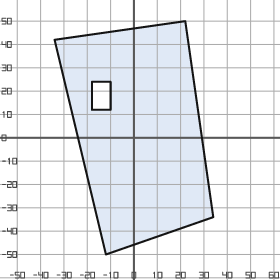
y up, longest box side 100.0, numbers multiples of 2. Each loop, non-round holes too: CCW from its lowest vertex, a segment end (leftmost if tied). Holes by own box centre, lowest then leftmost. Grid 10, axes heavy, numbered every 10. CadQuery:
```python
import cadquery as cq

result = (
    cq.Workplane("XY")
    .moveTo(-12.0, -50.0)
    .lineTo(34.0, -34.0)
    .lineTo(22.0, 50.0)
    .lineTo(-34.0, 42.0)
    .close()
    .moveTo(-18.0, 12.0)
    .lineTo(-10.0, 12.0)
    .lineTo(-10.0, 24.0)
    .lineTo(-18.0, 24.0)
    .close()
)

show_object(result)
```